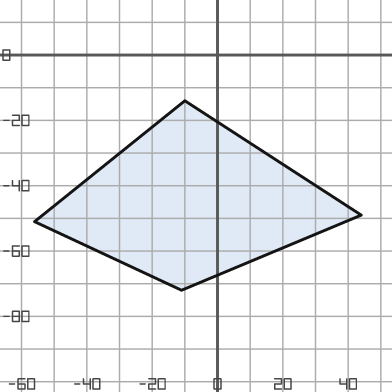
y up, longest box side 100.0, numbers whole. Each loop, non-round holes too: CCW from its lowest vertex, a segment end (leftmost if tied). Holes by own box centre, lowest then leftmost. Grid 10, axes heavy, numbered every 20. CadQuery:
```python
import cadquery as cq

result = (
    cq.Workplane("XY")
    .moveTo(-11.0, -72.0)
    .lineTo(44.0, -49.0)
    .lineTo(-10.0, -14.0)
    .lineTo(-56.0, -51.0)
    .close()
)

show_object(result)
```